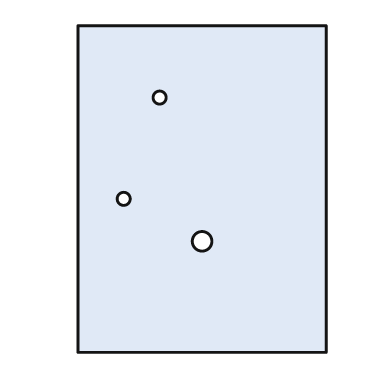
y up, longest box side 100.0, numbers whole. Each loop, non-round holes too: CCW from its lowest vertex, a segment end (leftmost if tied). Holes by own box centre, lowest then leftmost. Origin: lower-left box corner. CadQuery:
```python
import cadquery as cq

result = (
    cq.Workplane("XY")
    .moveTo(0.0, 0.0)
    .lineTo(76.0, 0.0)
    .lineTo(76.0, 100.0)
    .lineTo(0.0, 100.0)
    .close()
    .moveTo(38.0, 34.0)
    .circle(3.0)
    .moveTo(14.0, 47.0)
    .circle(2.0)
    .moveTo(25.0, 78.0)
    .circle(2.0)
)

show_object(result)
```